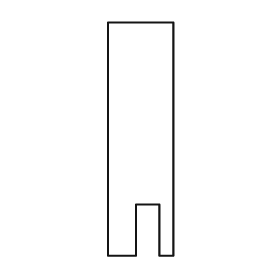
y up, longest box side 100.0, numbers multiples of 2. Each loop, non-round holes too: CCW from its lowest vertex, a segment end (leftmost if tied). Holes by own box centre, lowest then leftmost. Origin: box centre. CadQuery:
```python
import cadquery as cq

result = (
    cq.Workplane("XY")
    .moveTo(-14.0, -50.0)
    .lineTo(-2.0, -50.0)
    .lineTo(-2.0, -28.0)
    .lineTo(8.0, -28.0)
    .lineTo(8.0, -50.0)
    .lineTo(14.0, -50.0)
    .lineTo(14.0, 50.0)
    .lineTo(-14.0, 50.0)
    .close()
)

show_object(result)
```